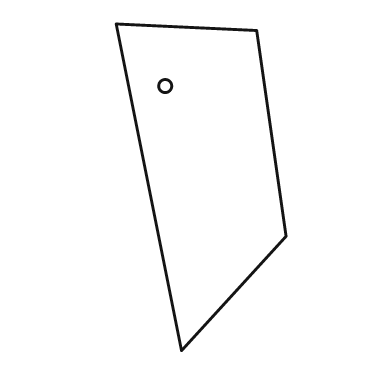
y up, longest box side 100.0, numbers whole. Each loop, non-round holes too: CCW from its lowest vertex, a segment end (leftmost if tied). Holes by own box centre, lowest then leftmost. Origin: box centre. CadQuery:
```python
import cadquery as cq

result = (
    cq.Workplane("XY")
    .moveTo(-6.0, -50.0)
    .lineTo(26.0, -15.0)
    .lineTo(17.0, 48.0)
    .lineTo(-26.0, 50.0)
    .close()
    .moveTo(-11.0, 31.0)
    .circle(2.0)
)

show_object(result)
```